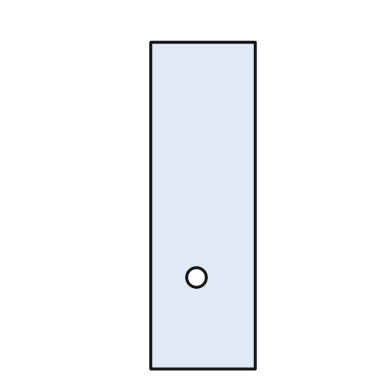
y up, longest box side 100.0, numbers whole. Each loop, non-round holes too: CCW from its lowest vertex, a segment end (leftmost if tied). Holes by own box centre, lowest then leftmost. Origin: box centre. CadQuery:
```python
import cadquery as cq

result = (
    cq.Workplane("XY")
    .moveTo(-16.0, -50.0)
    .lineTo(16.0, -50.0)
    .lineTo(16.0, 50.0)
    .lineTo(-16.0, 50.0)
    .close()
    .moveTo(-2.0, -22.0)
    .circle(3.0)
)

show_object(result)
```